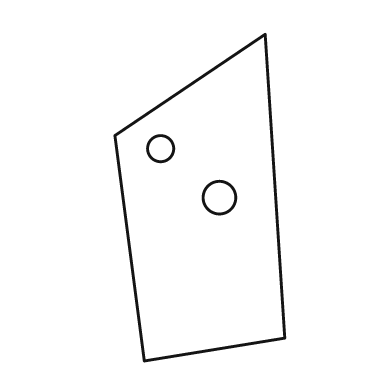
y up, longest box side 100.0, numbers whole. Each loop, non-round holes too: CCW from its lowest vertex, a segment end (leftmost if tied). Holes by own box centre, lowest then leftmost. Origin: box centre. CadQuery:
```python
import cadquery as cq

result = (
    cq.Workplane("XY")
    .moveTo(-17.0, -50.0)
    .lineTo(26.0, -43.0)
    .lineTo(20.0, 50.0)
    .lineTo(-26.0, 19.0)
    .close()
    .moveTo(6.0, 0.0)
    .circle(5.0)
    .moveTo(-12.0, 15.0)
    .circle(4.0)
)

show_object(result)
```